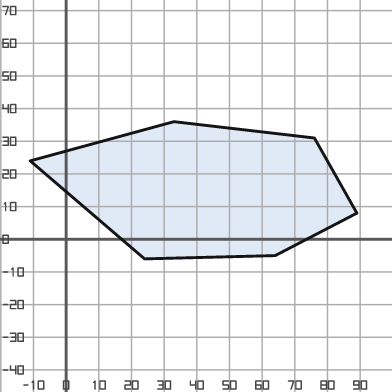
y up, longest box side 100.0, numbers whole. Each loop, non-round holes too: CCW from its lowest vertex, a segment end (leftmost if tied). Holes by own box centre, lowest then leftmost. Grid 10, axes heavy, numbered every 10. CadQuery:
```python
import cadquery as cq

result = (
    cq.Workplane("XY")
    .moveTo(24.0, -6.0)
    .lineTo(64.0, -5.0)
    .lineTo(89.0, 8.0)
    .lineTo(76.0, 31.0)
    .lineTo(33.0, 36.0)
    .lineTo(-11.0, 24.0)
    .close()
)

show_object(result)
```